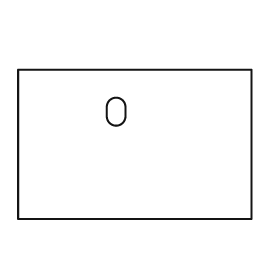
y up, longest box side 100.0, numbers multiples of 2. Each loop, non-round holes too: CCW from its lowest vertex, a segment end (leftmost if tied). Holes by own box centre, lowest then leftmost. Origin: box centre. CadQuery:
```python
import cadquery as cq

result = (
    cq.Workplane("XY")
    .moveTo(-50.0, -32.0)
    .lineTo(50.0, -32.0)
    .lineTo(50.0, 32.0)
    .lineTo(-50.0, 32.0)
    .close()
    .moveTo(-12.0, 12.0)
    .threePointArc((-8.0, 8.0), (-4.0, 12.0))
    .lineTo(-4.0, 16.0)
    .threePointArc((-8.0, 20.0), (-12.0, 16.0))
    .close()
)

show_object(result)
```